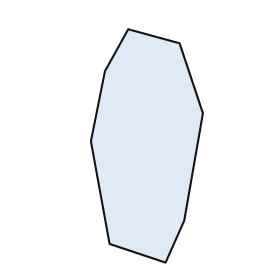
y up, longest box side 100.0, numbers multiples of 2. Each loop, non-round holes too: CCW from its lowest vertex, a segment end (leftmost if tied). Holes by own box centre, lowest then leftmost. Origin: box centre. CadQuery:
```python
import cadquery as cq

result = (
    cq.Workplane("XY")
    .moveTo(8.0, -50.0)
    .lineTo(16.0, -32.0)
    .lineTo(24.0, 14.0)
    .lineTo(14.0, 44.0)
    .lineTo(-8.0, 50.0)
    .lineTo(-18.0, 32.0)
    .lineTo(-24.0, 2.0)
    .lineTo(-16.0, -42.0)
    .close()
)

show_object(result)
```